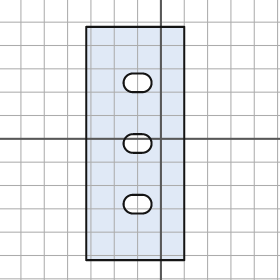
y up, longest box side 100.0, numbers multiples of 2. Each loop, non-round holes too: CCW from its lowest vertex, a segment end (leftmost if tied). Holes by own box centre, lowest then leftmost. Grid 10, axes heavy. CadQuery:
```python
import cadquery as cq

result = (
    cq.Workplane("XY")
    .moveTo(-32.0, -52.0)
    .lineTo(10.0, -52.0)
    .lineTo(10.0, 48.0)
    .lineTo(-32.0, 48.0)
    .close()
    .moveTo(-12.0, -32.0)
    .lineTo(-8.0, -32.0)
    .threePointArc((-4.0, -28.0), (-8.0, -24.0))
    .lineTo(-12.0, -24.0)
    .threePointArc((-16.0, -28.0), (-12.0, -32.0))
    .close()
    .moveTo(-12.0, -6.0)
    .lineTo(-8.0, -6.0)
    .threePointArc((-4.0, -2.0), (-8.0, 2.0))
    .lineTo(-12.0, 2.0)
    .threePointArc((-16.0, -2.0), (-12.0, -6.0))
    .close()
    .moveTo(-12.0, 20.0)
    .lineTo(-8.0, 20.0)
    .threePointArc((-4.0, 24.0), (-8.0, 28.0))
    .lineTo(-12.0, 28.0)
    .threePointArc((-16.0, 24.0), (-12.0, 20.0))
    .close()
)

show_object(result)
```